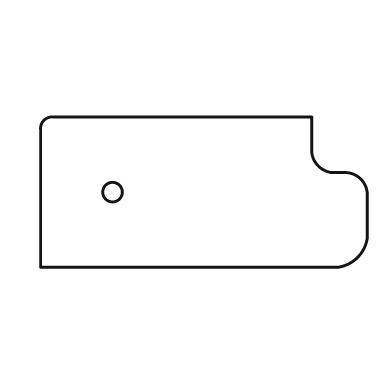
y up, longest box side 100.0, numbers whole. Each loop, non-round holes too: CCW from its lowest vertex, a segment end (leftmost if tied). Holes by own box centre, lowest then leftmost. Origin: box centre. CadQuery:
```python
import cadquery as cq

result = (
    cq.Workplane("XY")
    .moveTo(-50.0, -23.0)
    .lineTo(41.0, -23.0)
    .threePointArc((47.0, -20.0), (50.0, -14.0))
    .lineTo(50.0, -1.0)
    .threePointArc((48.0, 4.0), (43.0, 6.0))
    .lineTo(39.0, 6.0)
    .threePointArc((35.0, 8.0), (33.0, 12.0))
    .lineTo(33.0, 23.0)
    .lineTo(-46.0, 23.0)
    .threePointArc((-49.0, 22.0), (-50.0, 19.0))
    .close()
    .moveTo(-28.0, 0.0)
    .circle(3.0)
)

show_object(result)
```